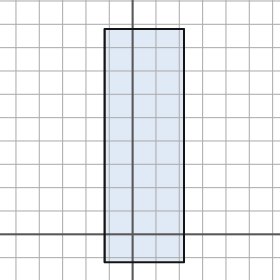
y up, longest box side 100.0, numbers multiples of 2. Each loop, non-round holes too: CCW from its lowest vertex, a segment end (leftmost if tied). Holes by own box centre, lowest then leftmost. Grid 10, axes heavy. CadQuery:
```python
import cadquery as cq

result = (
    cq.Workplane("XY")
    .moveTo(-12.0, -12.0)
    .lineTo(22.0, -12.0)
    .lineTo(22.0, 88.0)
    .lineTo(-12.0, 88.0)
    .close()
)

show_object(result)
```